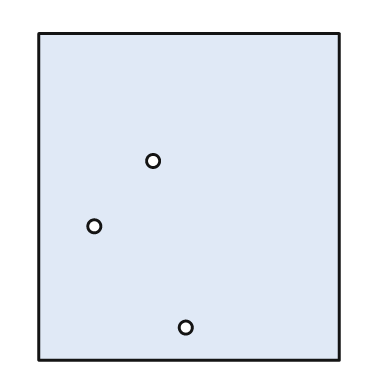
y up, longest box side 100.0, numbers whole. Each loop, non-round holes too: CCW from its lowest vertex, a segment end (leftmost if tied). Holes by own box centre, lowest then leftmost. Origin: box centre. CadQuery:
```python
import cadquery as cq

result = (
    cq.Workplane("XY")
    .moveTo(-46.0, -50.0)
    .lineTo(46.0, -50.0)
    .lineTo(46.0, 50.0)
    .lineTo(-46.0, 50.0)
    .close()
    .moveTo(-1.0, -40.0)
    .circle(2.0)
    .moveTo(-29.0, -9.0)
    .circle(2.0)
    .moveTo(-11.0, 11.0)
    .circle(2.0)
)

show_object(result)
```